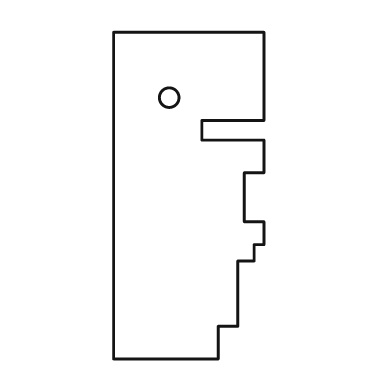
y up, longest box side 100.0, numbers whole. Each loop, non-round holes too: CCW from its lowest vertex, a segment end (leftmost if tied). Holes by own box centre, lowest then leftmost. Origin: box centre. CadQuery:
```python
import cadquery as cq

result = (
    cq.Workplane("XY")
    .moveTo(-23.0, -50.0)
    .lineTo(9.0, -50.0)
    .lineTo(9.0, -40.0)
    .lineTo(15.0, -40.0)
    .lineTo(15.0, -20.0)
    .lineTo(20.0, -20.0)
    .lineTo(20.0, -15.0)
    .lineTo(23.0, -15.0)
    .lineTo(23.0, -8.0)
    .lineTo(17.0, -8.0)
    .lineTo(17.0, 7.0)
    .lineTo(23.0, 7.0)
    .lineTo(23.0, 17.0)
    .lineTo(4.0, 17.0)
    .lineTo(4.0, 23.0)
    .lineTo(23.0, 23.0)
    .lineTo(23.0, 50.0)
    .lineTo(-23.0, 50.0)
    .close()
    .moveTo(-6.0, 30.0)
    .circle(3.0)
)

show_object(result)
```